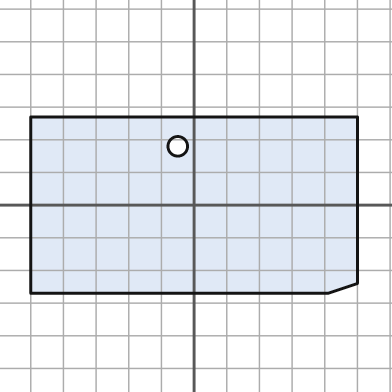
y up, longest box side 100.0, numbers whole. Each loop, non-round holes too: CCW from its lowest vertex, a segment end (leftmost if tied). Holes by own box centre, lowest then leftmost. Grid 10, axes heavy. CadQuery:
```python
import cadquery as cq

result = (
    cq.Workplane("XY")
    .moveTo(-50.0, -27.0)
    .lineTo(41.0, -27.0)
    .lineTo(50.0, -24.0)
    .lineTo(50.0, 27.0)
    .lineTo(-50.0, 27.0)
    .close()
    .moveTo(-5.0, 18.0)
    .circle(3.0)
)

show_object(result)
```